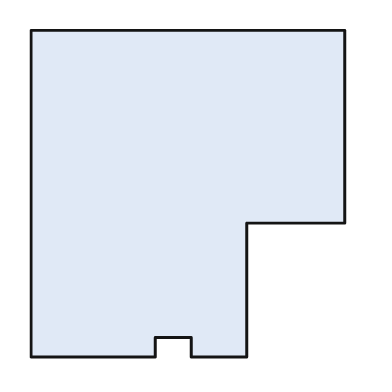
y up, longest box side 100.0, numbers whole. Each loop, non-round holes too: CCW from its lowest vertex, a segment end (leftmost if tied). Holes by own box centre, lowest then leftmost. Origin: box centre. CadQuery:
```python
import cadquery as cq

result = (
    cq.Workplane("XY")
    .moveTo(-48.0, -50.0)
    .lineTo(-10.0, -50.0)
    .lineTo(-10.0, -44.0)
    .lineTo(1.0, -44.0)
    .lineTo(1.0, -50.0)
    .lineTo(18.0, -50.0)
    .lineTo(18.0, -9.0)
    .lineTo(48.0, -9.0)
    .lineTo(48.0, 50.0)
    .lineTo(-48.0, 50.0)
    .close()
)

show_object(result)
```